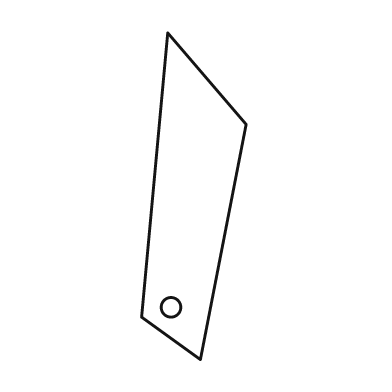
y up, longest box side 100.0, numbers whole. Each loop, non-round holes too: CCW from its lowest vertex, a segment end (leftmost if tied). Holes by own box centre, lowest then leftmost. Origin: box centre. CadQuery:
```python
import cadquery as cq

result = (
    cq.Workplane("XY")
    .moveTo(2.0, -50.0)
    .lineTo(16.0, 22.0)
    .lineTo(-8.0, 50.0)
    .lineTo(-16.0, -37.0)
    .close()
    .moveTo(-7.0, -34.0)
    .circle(3.0)
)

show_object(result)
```